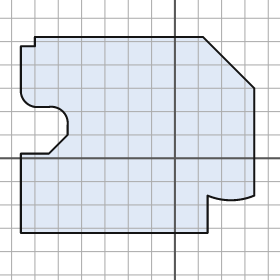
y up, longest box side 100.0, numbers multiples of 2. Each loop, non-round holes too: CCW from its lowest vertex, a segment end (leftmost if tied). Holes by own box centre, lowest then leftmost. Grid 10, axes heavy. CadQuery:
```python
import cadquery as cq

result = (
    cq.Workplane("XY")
    .moveTo(-66.0, -32.0)
    .lineTo(14.0, -32.0)
    .lineTo(14.0, -16.0)
    .threePointArc((24.0, -18.0), (34.0, -16.0))
    .lineTo(34.0, 30.0)
    .lineTo(12.0, 52.0)
    .lineTo(-60.0, 52.0)
    .lineTo(-60.0, 48.0)
    .lineTo(-66.0, 48.0)
    .lineTo(-66.0, 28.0)
    .threePointArc((-64.0, 24.0), (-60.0, 22.0))
    .lineTo(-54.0, 22.0)
    .threePointArc((-48.0, 20.0), (-46.0, 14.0))
    .lineTo(-46.0, 10.0)
    .lineTo(-54.0, 2.0)
    .lineTo(-66.0, 2.0)
    .close()
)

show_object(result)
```